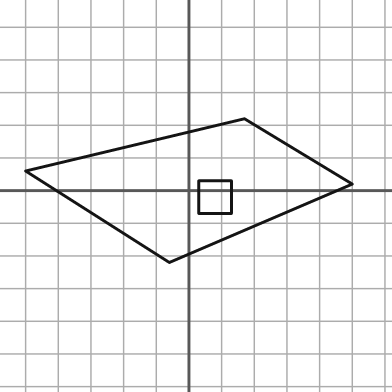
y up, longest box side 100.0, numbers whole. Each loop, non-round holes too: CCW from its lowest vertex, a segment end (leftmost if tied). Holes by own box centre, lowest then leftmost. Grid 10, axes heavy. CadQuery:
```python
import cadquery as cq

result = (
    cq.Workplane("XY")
    .moveTo(-6.0, -22.0)
    .lineTo(50.0, 2.0)
    .lineTo(17.0, 22.0)
    .lineTo(-50.0, 6.0)
    .close()
    .moveTo(3.0, -7.0)
    .lineTo(13.0, -7.0)
    .lineTo(13.0, 3.0)
    .lineTo(3.0, 3.0)
    .close()
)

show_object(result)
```